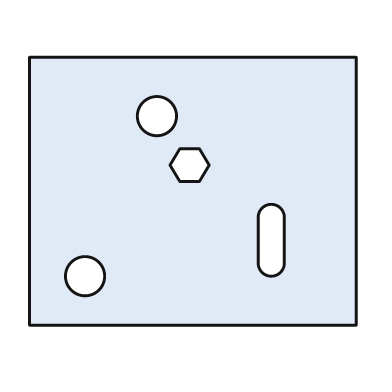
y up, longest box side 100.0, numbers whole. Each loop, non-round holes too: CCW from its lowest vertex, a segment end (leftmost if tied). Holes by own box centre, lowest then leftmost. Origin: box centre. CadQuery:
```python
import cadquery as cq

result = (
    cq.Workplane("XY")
    .moveTo(-50.0, -41.0)
    .lineTo(50.0, -41.0)
    .lineTo(50.0, 41.0)
    .lineTo(-50.0, 41.0)
    .close()
    .moveTo(-33.0, -26.0)
    .circle(6.0)
    .moveTo(20.0, -22.0)
    .threePointArc((24.0, -26.0), (28.0, -22.0))
    .lineTo(28.0, -8.0)
    .threePointArc((24.0, -4.0), (20.0, -8.0))
    .close()
    .moveTo(-4.0, 3.0)
    .lineTo(2.0, 3.0)
    .lineTo(5.0, 8.0)
    .lineTo(2.0, 13.0)
    .lineTo(-4.0, 13.0)
    .lineTo(-7.0, 8.0)
    .close()
    .moveTo(-11.0, 23.0)
    .circle(6.0)
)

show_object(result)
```